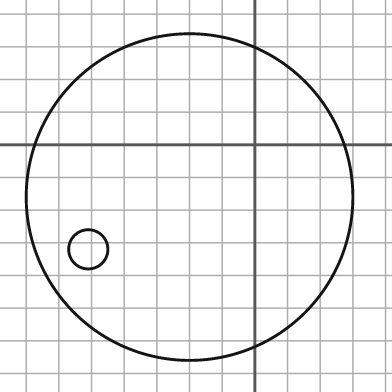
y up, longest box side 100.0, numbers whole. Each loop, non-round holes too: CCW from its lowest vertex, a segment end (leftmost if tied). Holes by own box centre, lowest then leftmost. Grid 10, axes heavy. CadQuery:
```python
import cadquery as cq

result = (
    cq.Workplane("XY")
    .moveTo(-20.0, -16.0)
    .circle(50.0)
    .moveTo(-51.0, -32.0)
    .circle(6.0)
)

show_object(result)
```